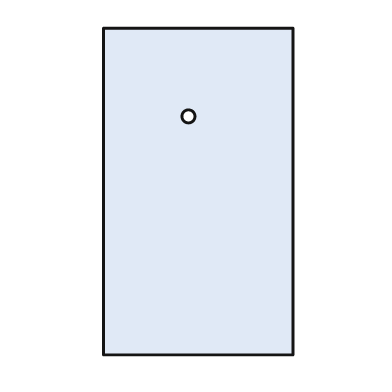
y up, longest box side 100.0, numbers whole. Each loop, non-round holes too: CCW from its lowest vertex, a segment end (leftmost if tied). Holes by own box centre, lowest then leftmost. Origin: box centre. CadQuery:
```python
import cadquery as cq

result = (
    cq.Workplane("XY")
    .moveTo(-29.0, -50.0)
    .lineTo(29.0, -50.0)
    .lineTo(29.0, 50.0)
    .lineTo(-29.0, 50.0)
    .close()
    .moveTo(-3.0, 23.0)
    .circle(2.0)
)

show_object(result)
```